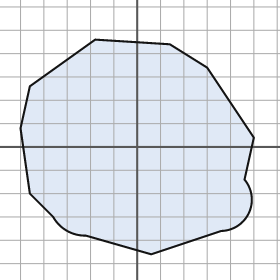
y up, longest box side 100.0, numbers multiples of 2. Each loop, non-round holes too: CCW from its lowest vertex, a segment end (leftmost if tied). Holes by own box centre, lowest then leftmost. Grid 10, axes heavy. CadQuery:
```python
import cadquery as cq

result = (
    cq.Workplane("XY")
    .moveTo(6.0, -46.0)
    .lineTo(36.0, -36.0)
    .threePointArc((48.0, -28.0), (46.0, -14.0))
    .lineTo(50.0, 4.0)
    .lineTo(30.0, 34.0)
    .lineTo(14.0, 44.0)
    .lineTo(-18.0, 46.0)
    .lineTo(-46.0, 26.0)
    .lineTo(-50.0, 8.0)
    .lineTo(-46.0, -20.0)
    .lineTo(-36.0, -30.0)
    .threePointArc((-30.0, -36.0), (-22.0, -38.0))
    .close()
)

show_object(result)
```